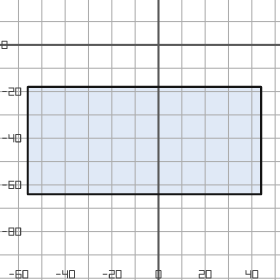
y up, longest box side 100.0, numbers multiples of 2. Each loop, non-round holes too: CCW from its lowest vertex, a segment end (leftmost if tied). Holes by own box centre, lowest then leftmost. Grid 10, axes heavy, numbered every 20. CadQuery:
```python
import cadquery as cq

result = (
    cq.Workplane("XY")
    .moveTo(-56.0, -64.0)
    .lineTo(44.0, -64.0)
    .lineTo(44.0, -18.0)
    .lineTo(-56.0, -18.0)
    .close()
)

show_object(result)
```